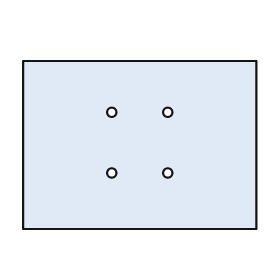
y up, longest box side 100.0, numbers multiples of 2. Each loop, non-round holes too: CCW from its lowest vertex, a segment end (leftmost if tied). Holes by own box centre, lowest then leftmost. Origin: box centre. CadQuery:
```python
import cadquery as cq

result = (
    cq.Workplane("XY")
    .moveTo(-50.0, -36.0)
    .lineTo(50.0, -36.0)
    .lineTo(50.0, 36.0)
    .lineTo(-50.0, 36.0)
    .close()
    .moveTo(-12.0, -12.0)
    .circle(2.0)
    .moveTo(12.0, -12.0)
    .circle(2.0)
    .moveTo(-12.0, 14.0)
    .circle(2.0)
    .moveTo(12.0, 14.0)
    .circle(2.0)
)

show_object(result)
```